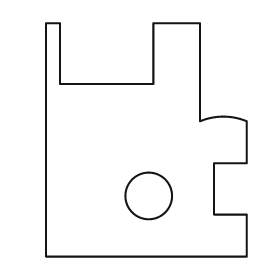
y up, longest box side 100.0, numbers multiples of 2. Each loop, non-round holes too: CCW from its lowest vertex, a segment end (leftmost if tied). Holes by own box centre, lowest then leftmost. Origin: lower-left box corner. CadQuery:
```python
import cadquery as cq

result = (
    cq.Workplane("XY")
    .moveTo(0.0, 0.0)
    .lineTo(86.0, 0.0)
    .lineTo(86.0, 18.0)
    .lineTo(72.0, 18.0)
    .lineTo(72.0, 40.0)
    .lineTo(86.0, 40.0)
    .lineTo(86.0, 58.0)
    .threePointArc((76.0, 60.0), (66.0, 58.0))
    .lineTo(66.0, 100.0)
    .lineTo(46.0, 100.0)
    .lineTo(46.0, 74.0)
    .lineTo(6.0, 74.0)
    .lineTo(6.0, 100.0)
    .lineTo(0.0, 100.0)
    .close()
    .moveTo(44.0, 26.0)
    .circle(10.0)
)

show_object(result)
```